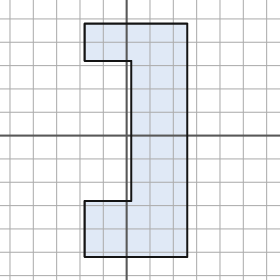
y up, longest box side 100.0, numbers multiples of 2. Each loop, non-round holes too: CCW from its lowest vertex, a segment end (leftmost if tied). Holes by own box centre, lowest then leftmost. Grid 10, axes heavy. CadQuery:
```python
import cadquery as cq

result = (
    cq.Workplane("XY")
    .moveTo(-18.0, -52.0)
    .lineTo(26.0, -52.0)
    .lineTo(26.0, 48.0)
    .lineTo(-18.0, 48.0)
    .lineTo(-18.0, 32.0)
    .lineTo(2.0, 32.0)
    .lineTo(2.0, -28.0)
    .lineTo(-18.0, -28.0)
    .close()
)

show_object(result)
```